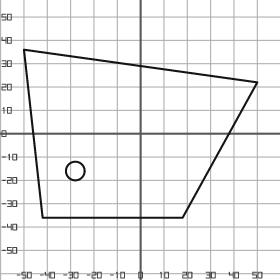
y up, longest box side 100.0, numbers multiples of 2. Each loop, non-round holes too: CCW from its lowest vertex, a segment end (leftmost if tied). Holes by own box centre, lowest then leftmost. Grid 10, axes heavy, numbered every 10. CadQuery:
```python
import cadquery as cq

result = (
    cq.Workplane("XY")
    .moveTo(-42.0, -36.0)
    .lineTo(18.0, -36.0)
    .lineTo(50.0, 22.0)
    .lineTo(-50.0, 36.0)
    .close()
    .moveTo(-28.0, -16.0)
    .circle(4.0)
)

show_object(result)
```